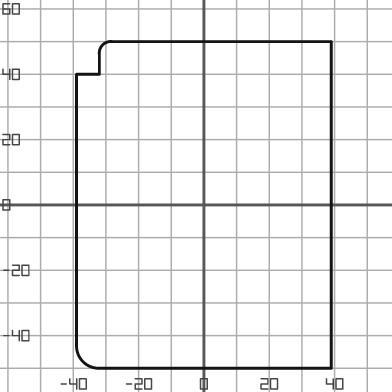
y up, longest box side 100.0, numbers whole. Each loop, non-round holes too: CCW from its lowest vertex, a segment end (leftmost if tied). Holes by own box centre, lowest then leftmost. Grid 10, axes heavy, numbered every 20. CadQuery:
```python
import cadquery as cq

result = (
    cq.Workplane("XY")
    .moveTo(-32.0, -50.0)
    .lineTo(39.0, -50.0)
    .lineTo(39.0, 50.0)
    .lineTo(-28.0, 50.0)
    .threePointArc((-31.0, 49.0), (-32.0, 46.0))
    .lineTo(-32.0, 40.0)
    .lineTo(-39.0, 40.0)
    .lineTo(-39.0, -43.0)
    .threePointArc((-37.0, -48.0), (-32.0, -50.0))
    .close()
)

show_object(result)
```